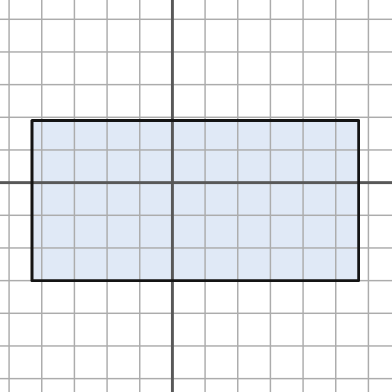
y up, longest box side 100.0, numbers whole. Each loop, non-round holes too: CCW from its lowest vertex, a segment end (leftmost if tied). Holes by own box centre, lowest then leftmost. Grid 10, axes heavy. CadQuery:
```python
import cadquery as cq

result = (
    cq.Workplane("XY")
    .moveTo(-43.0, -30.0)
    .lineTo(57.0, -30.0)
    .lineTo(57.0, 19.0)
    .lineTo(-43.0, 19.0)
    .close()
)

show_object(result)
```